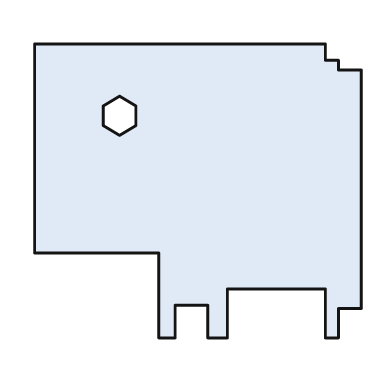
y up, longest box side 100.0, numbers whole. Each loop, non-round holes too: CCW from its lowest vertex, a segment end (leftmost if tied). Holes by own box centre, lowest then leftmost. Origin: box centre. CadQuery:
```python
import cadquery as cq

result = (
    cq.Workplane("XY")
    .moveTo(-12.0, -45.0)
    .lineTo(-7.0, -45.0)
    .lineTo(-7.0, -35.0)
    .lineTo(3.0, -35.0)
    .lineTo(3.0, -45.0)
    .lineTo(9.0, -45.0)
    .lineTo(9.0, -30.0)
    .lineTo(39.0, -30.0)
    .lineTo(39.0, -45.0)
    .lineTo(43.0, -45.0)
    .lineTo(43.0, -36.0)
    .lineTo(50.0, -36.0)
    .lineTo(50.0, 37.0)
    .lineTo(43.0, 37.0)
    .lineTo(43.0, 40.0)
    .lineTo(39.0, 40.0)
    .lineTo(39.0, 45.0)
    .lineTo(-50.0, 45.0)
    .lineTo(-50.0, -19.0)
    .lineTo(-12.0, -19.0)
    .close()
    .moveTo(-24.0, 17.0)
    .lineTo(-19.0, 20.0)
    .lineTo(-19.0, 26.0)
    .lineTo(-24.0, 29.0)
    .lineTo(-29.0, 26.0)
    .lineTo(-29.0, 20.0)
    .close()
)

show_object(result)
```